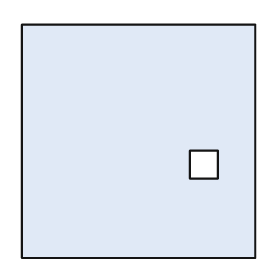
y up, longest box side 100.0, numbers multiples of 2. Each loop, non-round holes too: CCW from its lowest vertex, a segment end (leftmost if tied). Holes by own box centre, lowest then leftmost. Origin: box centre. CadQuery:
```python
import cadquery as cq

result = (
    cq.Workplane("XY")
    .moveTo(-50.0, -50.0)
    .lineTo(50.0, -50.0)
    .lineTo(50.0, 50.0)
    .lineTo(-50.0, 50.0)
    .close()
    .moveTo(22.0, -16.0)
    .lineTo(34.0, -16.0)
    .lineTo(34.0, -4.0)
    .lineTo(22.0, -4.0)
    .close()
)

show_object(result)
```